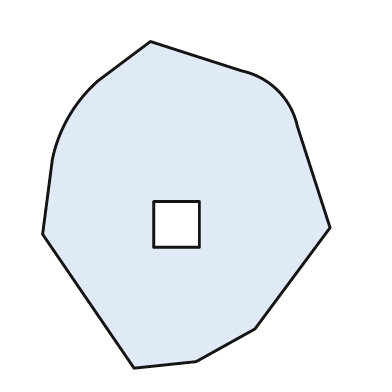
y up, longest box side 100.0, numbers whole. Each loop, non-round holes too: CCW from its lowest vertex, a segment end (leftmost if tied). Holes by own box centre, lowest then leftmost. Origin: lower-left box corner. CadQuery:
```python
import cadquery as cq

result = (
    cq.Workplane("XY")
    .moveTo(28.0, 0.0)
    .lineTo(47.0, 2.0)
    .lineTo(65.0, 12.0)
    .lineTo(88.0, 43.0)
    .lineTo(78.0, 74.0)
    .threePointArc((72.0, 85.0), (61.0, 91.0))
    .lineTo(33.0, 100.0)
    .lineTo(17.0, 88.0)
    .threePointArc((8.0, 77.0), (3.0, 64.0))
    .lineTo(0.0, 41.0)
    .close()
    .moveTo(34.0, 37.0)
    .lineTo(48.0, 37.0)
    .lineTo(48.0, 51.0)
    .lineTo(34.0, 51.0)
    .close()
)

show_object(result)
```